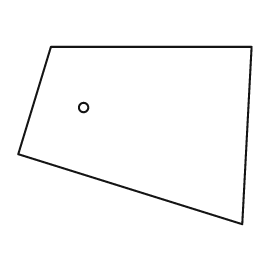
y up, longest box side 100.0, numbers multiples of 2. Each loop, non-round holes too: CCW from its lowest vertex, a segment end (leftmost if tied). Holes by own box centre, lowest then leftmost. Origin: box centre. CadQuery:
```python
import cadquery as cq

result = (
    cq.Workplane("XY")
    .moveTo(46.0, -38.0)
    .lineTo(50.0, 38.0)
    .lineTo(-36.0, 38.0)
    .lineTo(-50.0, -8.0)
    .close()
    .moveTo(-22.0, 12.0)
    .circle(2.0)
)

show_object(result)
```